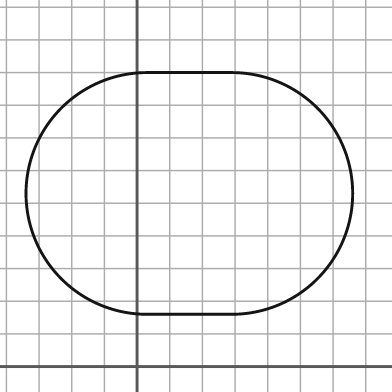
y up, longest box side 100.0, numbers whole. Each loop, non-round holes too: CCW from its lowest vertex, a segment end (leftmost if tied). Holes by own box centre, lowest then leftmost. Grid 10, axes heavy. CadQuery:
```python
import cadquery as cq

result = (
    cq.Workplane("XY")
    .moveTo(3.0, 16.0)
    .lineTo(29.0, 16.0)
    .threePointArc((66.0, 53.0), (29.0, 90.0))
    .lineTo(3.0, 90.0)
    .threePointArc((-34.0, 53.0), (3.0, 16.0))
    .close()
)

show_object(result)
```